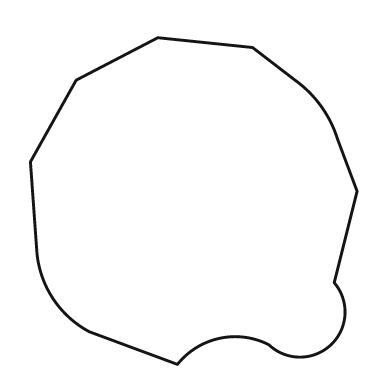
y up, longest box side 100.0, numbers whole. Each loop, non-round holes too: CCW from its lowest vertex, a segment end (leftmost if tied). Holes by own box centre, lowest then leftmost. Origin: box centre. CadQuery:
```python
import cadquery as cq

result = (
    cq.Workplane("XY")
    .moveTo(-5.0, -50.0)
    .threePointArc((8.0, -42.0), (23.0, -44.0))
    .threePointArc((42.0, -44.0), (43.0, -25.0))
    .lineTo(50.0, 3.0)
    .lineTo(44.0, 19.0)
    .threePointArc((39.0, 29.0), (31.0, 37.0))
    .lineTo(18.0, 47.0)
    .lineTo(-11.0, 50.0)
    .lineTo(-36.0, 37.0)
    .lineTo(-50.0, 12.0)
    .lineTo(-48.0, -16.0)
    .threePointArc((-43.0, -30.0), (-32.0, -40.0))
    .close()
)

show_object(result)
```